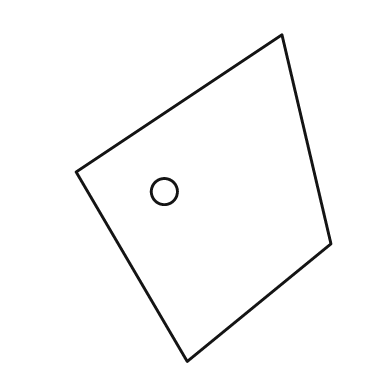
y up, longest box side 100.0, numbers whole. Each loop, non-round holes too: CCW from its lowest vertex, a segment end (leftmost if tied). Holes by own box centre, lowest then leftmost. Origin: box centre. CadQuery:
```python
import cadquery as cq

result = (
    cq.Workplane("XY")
    .moveTo(-5.0, -50.0)
    .lineTo(39.0, -14.0)
    .lineTo(24.0, 50.0)
    .lineTo(-39.0, 8.0)
    .close()
    .moveTo(-12.0, 2.0)
    .circle(4.0)
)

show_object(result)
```